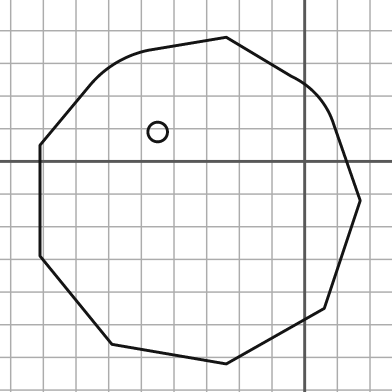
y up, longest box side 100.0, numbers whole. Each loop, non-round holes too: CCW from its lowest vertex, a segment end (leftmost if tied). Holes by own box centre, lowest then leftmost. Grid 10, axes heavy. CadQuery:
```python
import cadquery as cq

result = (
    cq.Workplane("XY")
    .moveTo(-24.0, -62.0)
    .lineTo(6.0, -45.0)
    .lineTo(17.0, -12.0)
    .lineTo(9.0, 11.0)
    .threePointArc((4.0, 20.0), (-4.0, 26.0))
    .lineTo(-24.0, 38.0)
    .lineTo(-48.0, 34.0)
    .threePointArc((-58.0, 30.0), (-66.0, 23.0))
    .lineTo(-81.0, 5.0)
    .lineTo(-81.0, -29.0)
    .lineTo(-59.0, -56.0)
    .close()
    .moveTo(-45.0, 9.0)
    .circle(3.0)
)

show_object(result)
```